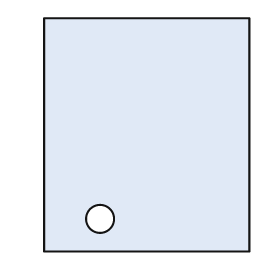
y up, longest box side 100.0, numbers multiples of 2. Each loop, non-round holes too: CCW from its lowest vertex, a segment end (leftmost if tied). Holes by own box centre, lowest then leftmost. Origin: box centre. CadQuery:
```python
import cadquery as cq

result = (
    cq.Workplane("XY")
    .moveTo(-44.0, -50.0)
    .lineTo(44.0, -50.0)
    .lineTo(44.0, 50.0)
    .lineTo(-44.0, 50.0)
    .close()
    .moveTo(-20.0, -36.0)
    .circle(6.0)
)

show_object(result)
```